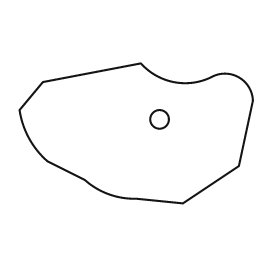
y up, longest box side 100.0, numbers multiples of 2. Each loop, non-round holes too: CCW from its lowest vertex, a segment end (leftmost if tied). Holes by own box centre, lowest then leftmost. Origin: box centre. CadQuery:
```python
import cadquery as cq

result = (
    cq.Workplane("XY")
    .moveTo(20.0, -30.0)
    .lineTo(44.0, -14.0)
    .lineTo(50.0, 14.0)
    .threePointArc((44.0, 24.0), (32.0, 24.0))
    .threePointArc((16.0, 22.0), (2.0, 30.0))
    .lineTo(-40.0, 22.0)
    .lineTo(-50.0, 10.0)
    .threePointArc((-46.0, -2.0), (-38.0, -12.0))
    .lineTo(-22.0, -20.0)
    .threePointArc((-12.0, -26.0), (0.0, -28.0))
    .close()
    .moveTo(10.0, 6.0)
    .circle(4.0)
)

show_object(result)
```